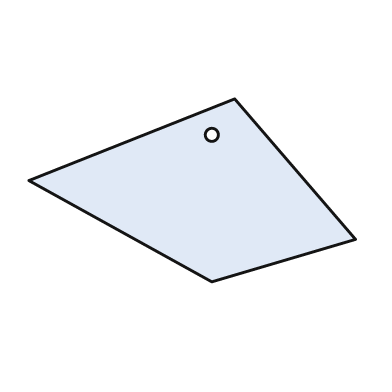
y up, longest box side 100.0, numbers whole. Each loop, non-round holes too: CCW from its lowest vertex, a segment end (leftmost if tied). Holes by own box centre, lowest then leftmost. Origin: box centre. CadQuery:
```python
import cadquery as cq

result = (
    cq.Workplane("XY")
    .moveTo(6.0, -28.0)
    .lineTo(50.0, -15.0)
    .lineTo(13.0, 28.0)
    .lineTo(-50.0, 3.0)
    .close()
    .moveTo(6.0, 17.0)
    .circle(2.0)
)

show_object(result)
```